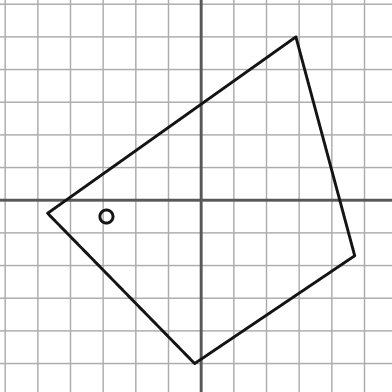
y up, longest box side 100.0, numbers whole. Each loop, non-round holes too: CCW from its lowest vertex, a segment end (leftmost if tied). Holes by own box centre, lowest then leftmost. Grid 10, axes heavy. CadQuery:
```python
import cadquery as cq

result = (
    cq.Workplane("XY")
    .moveTo(-2.0, -50.0)
    .lineTo(47.0, -17.0)
    .lineTo(29.0, 50.0)
    .lineTo(-47.0, -4.0)
    .close()
    .moveTo(-29.0, -5.0)
    .circle(2.0)
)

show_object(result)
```